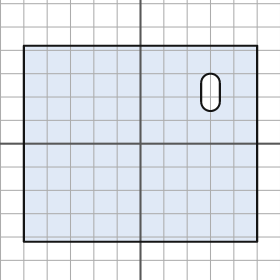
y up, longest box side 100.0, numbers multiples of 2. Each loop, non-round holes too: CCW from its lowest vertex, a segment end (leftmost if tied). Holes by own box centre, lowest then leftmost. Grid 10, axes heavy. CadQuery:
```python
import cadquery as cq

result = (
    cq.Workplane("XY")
    .moveTo(-50.0, -42.0)
    .lineTo(50.0, -42.0)
    .lineTo(50.0, 42.0)
    .lineTo(-50.0, 42.0)
    .close()
    .moveTo(26.0, 18.0)
    .threePointArc((30.0, 14.0), (34.0, 18.0))
    .lineTo(34.0, 26.0)
    .threePointArc((30.0, 30.0), (26.0, 26.0))
    .close()
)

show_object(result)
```